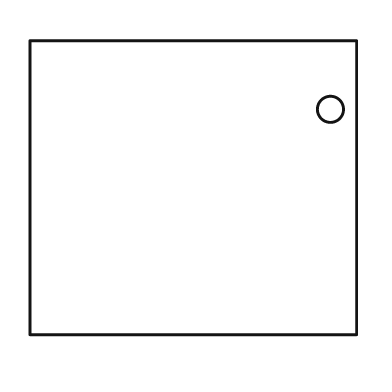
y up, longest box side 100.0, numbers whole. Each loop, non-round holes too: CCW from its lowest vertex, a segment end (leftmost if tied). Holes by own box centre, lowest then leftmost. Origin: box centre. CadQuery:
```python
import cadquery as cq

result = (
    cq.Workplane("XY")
    .moveTo(-50.0, -45.0)
    .lineTo(50.0, -45.0)
    .lineTo(50.0, 45.0)
    .lineTo(-50.0, 45.0)
    .close()
    .moveTo(42.0, 24.0)
    .circle(4.0)
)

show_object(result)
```